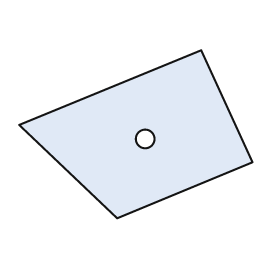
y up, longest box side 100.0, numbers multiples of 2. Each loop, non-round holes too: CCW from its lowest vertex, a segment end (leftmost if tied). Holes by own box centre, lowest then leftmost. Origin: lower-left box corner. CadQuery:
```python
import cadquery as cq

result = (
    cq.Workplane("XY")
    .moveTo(42.0, 0.0)
    .lineTo(100.0, 24.0)
    .lineTo(78.0, 72.0)
    .lineTo(0.0, 40.0)
    .close()
    .moveTo(54.0, 34.0)
    .circle(4.0)
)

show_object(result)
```